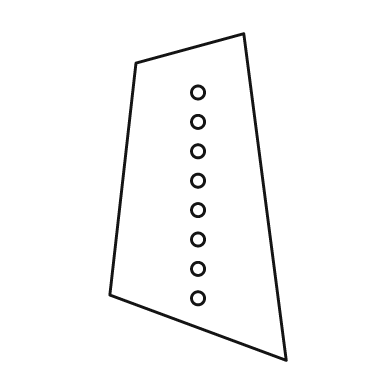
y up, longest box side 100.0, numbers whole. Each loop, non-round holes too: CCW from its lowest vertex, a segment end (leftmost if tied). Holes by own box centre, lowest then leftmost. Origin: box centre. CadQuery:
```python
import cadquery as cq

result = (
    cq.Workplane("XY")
    .moveTo(27.0, -50.0)
    .lineTo(14.0, 50.0)
    .lineTo(-19.0, 41.0)
    .lineTo(-27.0, -30.0)
    .close()
    .moveTo(0.0, -31.0)
    .circle(2.0)
    .moveTo(0.0, -22.0)
    .circle(2.0)
    .moveTo(0.0, -13.0)
    .circle(2.0)
    .moveTo(0.0, -4.0)
    .circle(2.0)
    .moveTo(0.0, 5.0)
    .circle(2.0)
    .moveTo(0.0, 14.0)
    .circle(2.0)
    .moveTo(0.0, 23.0)
    .circle(2.0)
    .moveTo(0.0, 32.0)
    .circle(2.0)
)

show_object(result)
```